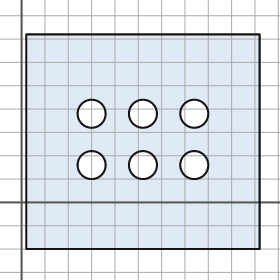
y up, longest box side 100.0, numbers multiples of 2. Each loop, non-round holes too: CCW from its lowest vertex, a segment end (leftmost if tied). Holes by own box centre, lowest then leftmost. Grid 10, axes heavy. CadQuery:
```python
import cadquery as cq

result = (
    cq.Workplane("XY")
    .moveTo(2.0, -20.0)
    .lineTo(102.0, -20.0)
    .lineTo(102.0, 72.0)
    .lineTo(2.0, 72.0)
    .close()
    .moveTo(30.0, 16.0)
    .circle(6.0)
    .moveTo(52.0, 16.0)
    .circle(6.0)
    .moveTo(74.0, 16.0)
    .circle(6.0)
    .moveTo(30.0, 38.0)
    .circle(6.0)
    .moveTo(52.0, 38.0)
    .circle(6.0)
    .moveTo(74.0, 38.0)
    .circle(6.0)
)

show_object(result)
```